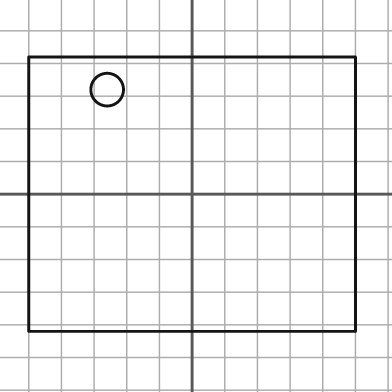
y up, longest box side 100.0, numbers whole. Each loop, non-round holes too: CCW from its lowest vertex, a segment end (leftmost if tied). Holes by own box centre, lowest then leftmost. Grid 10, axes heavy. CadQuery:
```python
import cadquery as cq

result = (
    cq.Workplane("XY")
    .moveTo(-50.0, -42.0)
    .lineTo(50.0, -42.0)
    .lineTo(50.0, 42.0)
    .lineTo(-50.0, 42.0)
    .close()
    .moveTo(-26.0, 32.0)
    .circle(5.0)
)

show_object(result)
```